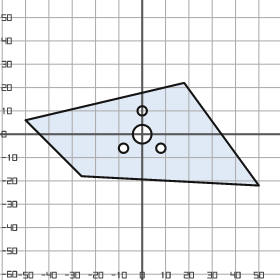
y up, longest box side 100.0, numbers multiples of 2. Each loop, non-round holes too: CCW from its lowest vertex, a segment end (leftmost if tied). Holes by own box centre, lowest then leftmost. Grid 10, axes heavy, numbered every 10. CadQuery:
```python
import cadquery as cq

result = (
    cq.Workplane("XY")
    .moveTo(50.0, -22.0)
    .lineTo(18.0, 22.0)
    .lineTo(-50.0, 6.0)
    .lineTo(-26.0, -18.0)
    .close()
    .moveTo(-8.0, -6.0)
    .circle(2.0)
    .moveTo(8.0, -6.0)
    .circle(2.0)
    .moveTo(0.0, 0.0)
    .circle(4.0)
    .moveTo(0.0, 10.0)
    .circle(2.0)
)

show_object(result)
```